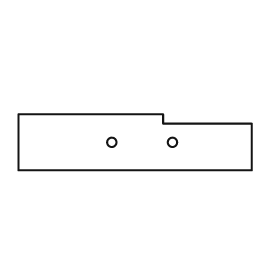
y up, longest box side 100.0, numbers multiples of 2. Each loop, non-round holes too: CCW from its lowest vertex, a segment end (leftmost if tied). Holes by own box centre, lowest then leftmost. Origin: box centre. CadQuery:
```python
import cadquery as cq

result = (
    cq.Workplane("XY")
    .moveTo(-50.0, -12.0)
    .lineTo(50.0, -12.0)
    .lineTo(50.0, 8.0)
    .lineTo(12.0, 8.0)
    .lineTo(12.0, 12.0)
    .lineTo(-50.0, 12.0)
    .close()
    .moveTo(-10.0, 0.0)
    .circle(2.0)
    .moveTo(16.0, 0.0)
    .circle(2.0)
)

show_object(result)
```